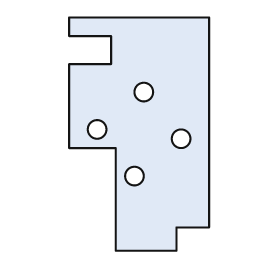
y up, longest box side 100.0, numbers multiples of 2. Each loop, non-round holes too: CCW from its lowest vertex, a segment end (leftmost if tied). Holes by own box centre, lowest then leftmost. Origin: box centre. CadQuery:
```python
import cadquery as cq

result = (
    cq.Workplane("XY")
    .moveTo(-10.0, -50.0)
    .lineTo(16.0, -50.0)
    .lineTo(16.0, -40.0)
    .lineTo(30.0, -40.0)
    .lineTo(30.0, 50.0)
    .lineTo(-30.0, 50.0)
    .lineTo(-30.0, 42.0)
    .lineTo(-12.0, 42.0)
    .lineTo(-12.0, 30.0)
    .lineTo(-30.0, 30.0)
    .lineTo(-30.0, -6.0)
    .lineTo(-10.0, -6.0)
    .close()
    .moveTo(-2.0, -18.0)
    .circle(4.0)
    .moveTo(18.0, -2.0)
    .circle(4.0)
    .moveTo(-18.0, 2.0)
    .circle(4.0)
    .moveTo(2.0, 18.0)
    .circle(4.0)
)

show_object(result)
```